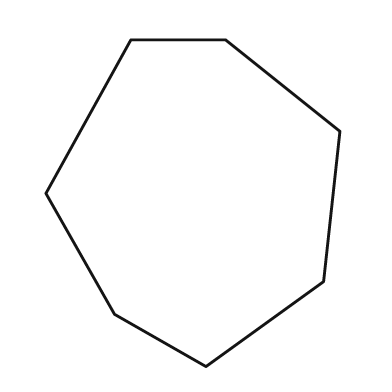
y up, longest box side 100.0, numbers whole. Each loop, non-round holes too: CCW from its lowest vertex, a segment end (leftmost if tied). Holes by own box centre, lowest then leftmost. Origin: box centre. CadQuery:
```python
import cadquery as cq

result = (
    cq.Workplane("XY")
    .moveTo(4.0, -50.0)
    .lineTo(40.0, -24.0)
    .lineTo(45.0, 22.0)
    .lineTo(10.0, 50.0)
    .lineTo(-19.0, 50.0)
    .lineTo(-45.0, 3.0)
    .lineTo(-24.0, -34.0)
    .close()
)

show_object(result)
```